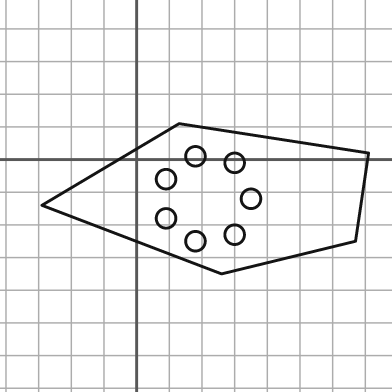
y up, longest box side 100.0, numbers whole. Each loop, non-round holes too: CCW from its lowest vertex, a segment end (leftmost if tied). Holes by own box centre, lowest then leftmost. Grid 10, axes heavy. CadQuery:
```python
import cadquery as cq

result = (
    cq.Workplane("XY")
    .moveTo(26.0, -35.0)
    .lineTo(67.0, -25.0)
    .lineTo(71.0, 2.0)
    .lineTo(13.0, 11.0)
    .lineTo(-29.0, -14.0)
    .close()
    .moveTo(18.0, -25.0)
    .circle(3.0)
    .moveTo(30.0, -23.0)
    .circle(3.0)
    .moveTo(9.0, -18.0)
    .circle(3.0)
    .moveTo(35.0, -12.0)
    .circle(3.0)
    .moveTo(9.0, -6.0)
    .circle(3.0)
    .moveTo(30.0, -1.0)
    .circle(3.0)
    .moveTo(18.0, 1.0)
    .circle(3.0)
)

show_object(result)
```